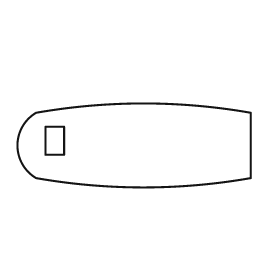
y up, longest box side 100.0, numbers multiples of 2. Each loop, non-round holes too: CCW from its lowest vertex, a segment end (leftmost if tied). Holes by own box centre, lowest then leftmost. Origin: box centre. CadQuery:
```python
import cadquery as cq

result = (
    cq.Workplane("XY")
    .moveTo(-42.0, -14.0)
    .threePointArc((4.0, -18.0), (50.0, -14.0))
    .lineTo(50.0, 14.0)
    .threePointArc((4.0, 18.0), (-42.0, 14.0))
    .threePointArc((-50.0, 0.0), (-42.0, -14.0))
    .close()
    .moveTo(-38.0, -4.0)
    .lineTo(-30.0, -4.0)
    .lineTo(-30.0, 8.0)
    .lineTo(-38.0, 8.0)
    .close()
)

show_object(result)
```